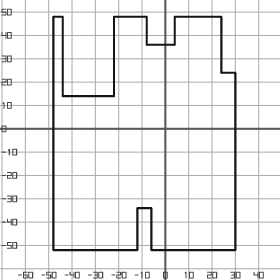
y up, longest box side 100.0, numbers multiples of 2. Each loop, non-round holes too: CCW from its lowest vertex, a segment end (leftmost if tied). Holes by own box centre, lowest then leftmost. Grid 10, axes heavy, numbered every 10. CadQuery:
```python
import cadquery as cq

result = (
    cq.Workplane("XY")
    .moveTo(-48.0, -52.0)
    .lineTo(-12.0, -52.0)
    .lineTo(-12.0, -34.0)
    .lineTo(-6.0, -34.0)
    .lineTo(-6.0, -52.0)
    .lineTo(30.0, -52.0)
    .lineTo(30.0, 24.0)
    .lineTo(24.0, 24.0)
    .lineTo(24.0, 48.0)
    .lineTo(4.0, 48.0)
    .lineTo(4.0, 36.0)
    .lineTo(-8.0, 36.0)
    .lineTo(-8.0, 48.0)
    .lineTo(-22.0, 48.0)
    .lineTo(-22.0, 14.0)
    .lineTo(-44.0, 14.0)
    .lineTo(-44.0, 48.0)
    .lineTo(-48.0, 48.0)
    .close()
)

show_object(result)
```